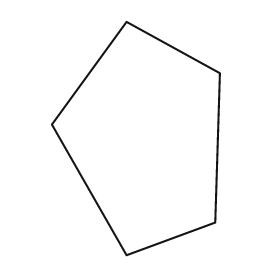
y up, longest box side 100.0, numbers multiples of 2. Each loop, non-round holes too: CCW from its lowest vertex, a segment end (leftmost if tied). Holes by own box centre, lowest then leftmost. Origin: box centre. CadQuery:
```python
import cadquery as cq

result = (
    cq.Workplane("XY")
    .moveTo(-4.0, -50.0)
    .lineTo(34.0, -36.0)
    .lineTo(36.0, 28.0)
    .lineTo(-4.0, 50.0)
    .lineTo(-36.0, 6.0)
    .close()
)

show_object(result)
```